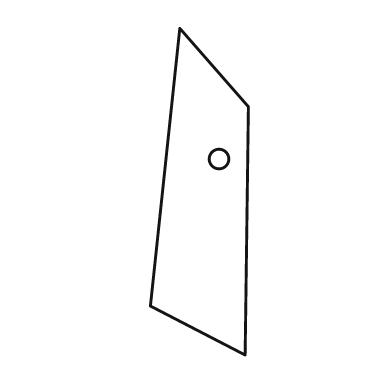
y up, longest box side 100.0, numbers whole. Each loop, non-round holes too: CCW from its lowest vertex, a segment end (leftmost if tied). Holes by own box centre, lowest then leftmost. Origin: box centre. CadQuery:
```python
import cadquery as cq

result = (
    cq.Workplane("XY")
    .moveTo(14.0, -50.0)
    .lineTo(15.0, 26.0)
    .lineTo(-6.0, 50.0)
    .lineTo(-15.0, -35.0)
    .close()
    .moveTo(6.0, 10.0)
    .circle(3.0)
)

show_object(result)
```